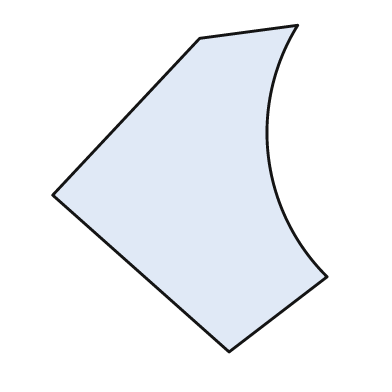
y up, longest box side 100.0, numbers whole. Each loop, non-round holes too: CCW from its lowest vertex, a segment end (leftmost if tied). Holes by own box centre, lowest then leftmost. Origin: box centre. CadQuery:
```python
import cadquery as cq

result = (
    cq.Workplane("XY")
    .moveTo(12.0, -50.0)
    .lineTo(42.0, -27.0)
    .threePointArc((24.0, 10.0), (33.0, 50.0))
    .lineTo(3.0, 46.0)
    .lineTo(-42.0, -2.0)
    .close()
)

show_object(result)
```